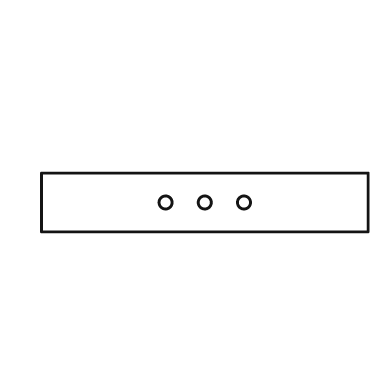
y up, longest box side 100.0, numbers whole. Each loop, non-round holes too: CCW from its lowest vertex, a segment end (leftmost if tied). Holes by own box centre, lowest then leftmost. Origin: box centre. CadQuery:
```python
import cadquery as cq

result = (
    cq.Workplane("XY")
    .moveTo(-50.0, -9.0)
    .lineTo(50.0, -9.0)
    .lineTo(50.0, 9.0)
    .lineTo(-50.0, 9.0)
    .close()
    .moveTo(-12.0, 0.0)
    .circle(2.0)
    .moveTo(0.0, 0.0)
    .circle(2.0)
    .moveTo(12.0, 0.0)
    .circle(2.0)
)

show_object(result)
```